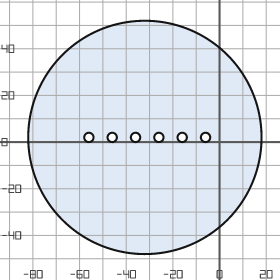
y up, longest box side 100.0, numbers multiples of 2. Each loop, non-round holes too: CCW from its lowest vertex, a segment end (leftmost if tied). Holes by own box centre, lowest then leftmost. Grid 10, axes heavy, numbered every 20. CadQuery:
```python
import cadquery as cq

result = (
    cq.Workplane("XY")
    .moveTo(-32.0, 2.0)
    .circle(50.0)
    .moveTo(-56.0, 2.0)
    .circle(2.0)
    .moveTo(-46.0, 2.0)
    .circle(2.0)
    .moveTo(-36.0, 2.0)
    .circle(2.0)
    .moveTo(-26.0, 2.0)
    .circle(2.0)
    .moveTo(-16.0, 2.0)
    .circle(2.0)
    .moveTo(-6.0, 2.0)
    .circle(2.0)
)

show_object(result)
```